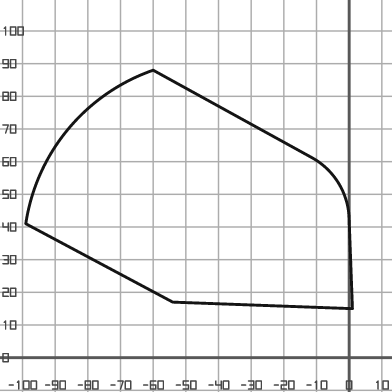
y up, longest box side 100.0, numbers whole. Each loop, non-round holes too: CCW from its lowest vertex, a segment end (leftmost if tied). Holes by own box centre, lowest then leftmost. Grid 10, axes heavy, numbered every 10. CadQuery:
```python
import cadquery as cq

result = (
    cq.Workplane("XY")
    .moveTo(1.0, 15.0)
    .lineTo(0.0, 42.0)
    .threePointArc((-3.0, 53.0), (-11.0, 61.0))
    .lineTo(-60.0, 88.0)
    .threePointArc((-86.0, 70.0), (-99.0, 41.0))
    .lineTo(-54.0, 17.0)
    .close()
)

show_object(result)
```